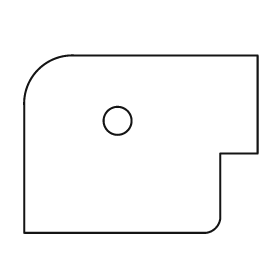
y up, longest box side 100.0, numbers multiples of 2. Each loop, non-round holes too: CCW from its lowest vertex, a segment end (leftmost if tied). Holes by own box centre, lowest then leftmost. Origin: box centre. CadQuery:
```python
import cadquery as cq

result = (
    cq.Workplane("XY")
    .moveTo(-50.0, -38.0)
    .lineTo(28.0, -38.0)
    .threePointArc((32.0, -36.0), (34.0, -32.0))
    .lineTo(34.0, -4.0)
    .lineTo(50.0, -4.0)
    .lineTo(50.0, 38.0)
    .lineTo(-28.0, 38.0)
    .threePointArc((-44.0, 32.0), (-50.0, 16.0))
    .close()
    .moveTo(-10.0, 10.0)
    .circle(6.0)
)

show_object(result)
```